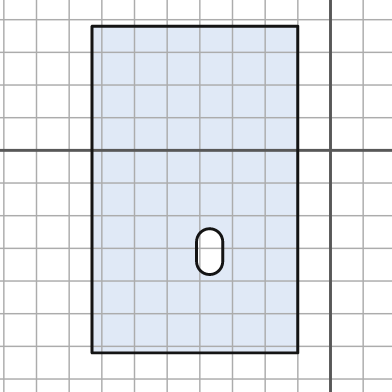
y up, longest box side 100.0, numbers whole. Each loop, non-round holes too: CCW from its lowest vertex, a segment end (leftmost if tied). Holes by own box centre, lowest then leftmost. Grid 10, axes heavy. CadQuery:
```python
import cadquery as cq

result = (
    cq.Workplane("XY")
    .moveTo(-73.0, -62.0)
    .lineTo(-10.0, -62.0)
    .lineTo(-10.0, 38.0)
    .lineTo(-73.0, 38.0)
    .close()
    .moveTo(-41.0, -34.0)
    .threePointArc((-37.0, -38.0), (-33.0, -34.0))
    .lineTo(-33.0, -28.0)
    .threePointArc((-37.0, -24.0), (-41.0, -28.0))
    .close()
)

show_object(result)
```